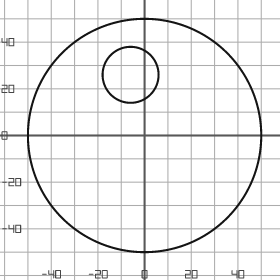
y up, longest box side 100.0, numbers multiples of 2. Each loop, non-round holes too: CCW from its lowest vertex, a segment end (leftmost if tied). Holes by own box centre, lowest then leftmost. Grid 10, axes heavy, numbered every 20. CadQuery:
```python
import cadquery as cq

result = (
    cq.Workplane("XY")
    .moveTo(0.0, 0.0)
    .circle(50.0)
    .moveTo(-6.0, 26.0)
    .circle(12.0)
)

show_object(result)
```